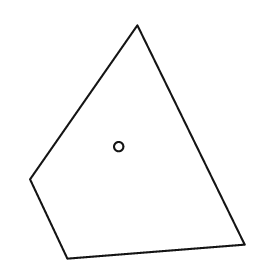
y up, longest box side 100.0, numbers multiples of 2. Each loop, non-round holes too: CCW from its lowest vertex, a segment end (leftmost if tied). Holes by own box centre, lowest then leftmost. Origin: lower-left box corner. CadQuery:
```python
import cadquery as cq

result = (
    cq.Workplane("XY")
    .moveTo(16.0, 0.0)
    .lineTo(92.0, 6.0)
    .lineTo(46.0, 100.0)
    .lineTo(0.0, 34.0)
    .close()
    .moveTo(38.0, 48.0)
    .circle(2.0)
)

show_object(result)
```